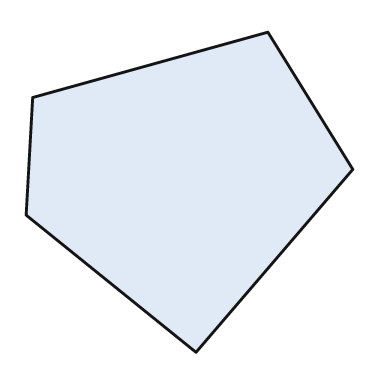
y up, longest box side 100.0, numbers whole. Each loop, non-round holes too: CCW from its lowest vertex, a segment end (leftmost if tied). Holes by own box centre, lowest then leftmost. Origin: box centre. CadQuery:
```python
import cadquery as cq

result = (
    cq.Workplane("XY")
    .moveTo(2.0, -49.0)
    .lineTo(50.0, 7.0)
    .lineTo(24.0, 49.0)
    .lineTo(-48.0, 29.0)
    .lineTo(-50.0, -7.0)
    .close()
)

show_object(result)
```